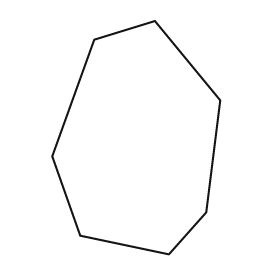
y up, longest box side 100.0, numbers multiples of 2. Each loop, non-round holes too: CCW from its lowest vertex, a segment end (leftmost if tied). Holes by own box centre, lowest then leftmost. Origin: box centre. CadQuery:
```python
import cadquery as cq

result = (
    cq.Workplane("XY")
    .moveTo(14.0, -50.0)
    .lineTo(30.0, -32.0)
    .lineTo(36.0, 16.0)
    .lineTo(8.0, 50.0)
    .lineTo(-18.0, 42.0)
    .lineTo(-36.0, -8.0)
    .lineTo(-24.0, -42.0)
    .close()
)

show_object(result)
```